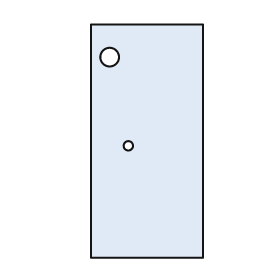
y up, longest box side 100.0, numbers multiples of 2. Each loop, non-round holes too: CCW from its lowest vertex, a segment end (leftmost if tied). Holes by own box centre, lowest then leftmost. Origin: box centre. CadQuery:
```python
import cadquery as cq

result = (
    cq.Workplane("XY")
    .moveTo(-24.0, -50.0)
    .lineTo(24.0, -50.0)
    .lineTo(24.0, 50.0)
    .lineTo(-24.0, 50.0)
    .close()
    .moveTo(-8.0, -2.0)
    .circle(2.0)
    .moveTo(-16.0, 36.0)
    .circle(4.0)
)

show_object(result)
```